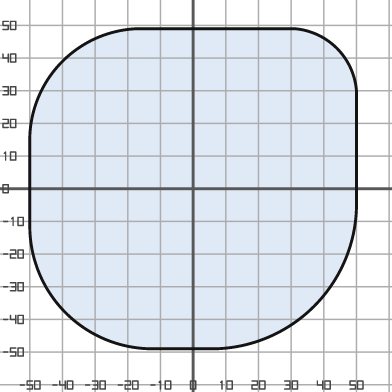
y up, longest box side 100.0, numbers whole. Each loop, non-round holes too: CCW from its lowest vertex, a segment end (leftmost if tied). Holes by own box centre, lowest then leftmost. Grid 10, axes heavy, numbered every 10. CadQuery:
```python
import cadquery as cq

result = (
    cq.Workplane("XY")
    .moveTo(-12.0, -49.0)
    .lineTo(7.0, -49.0)
    .threePointArc((37.0, -36.0), (50.0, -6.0))
    .lineTo(50.0, 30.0)
    .threePointArc((44.0, 43.0), (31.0, 49.0))
    .lineTo(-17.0, 49.0)
    .threePointArc((-40.0, 39.0), (-50.0, 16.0))
    .lineTo(-50.0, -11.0)
    .threePointArc((-39.0, -38.0), (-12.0, -49.0))
    .close()
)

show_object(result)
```